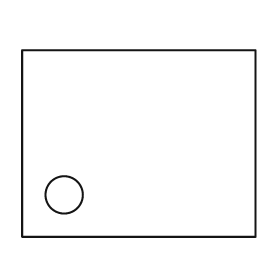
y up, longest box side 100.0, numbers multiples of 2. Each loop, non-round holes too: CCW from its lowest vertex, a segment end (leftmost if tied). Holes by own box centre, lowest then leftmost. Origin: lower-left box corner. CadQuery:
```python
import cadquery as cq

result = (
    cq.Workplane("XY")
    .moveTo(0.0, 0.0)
    .lineTo(100.0, 0.0)
    .lineTo(100.0, 80.0)
    .lineTo(0.0, 80.0)
    .close()
    .moveTo(18.0, 18.0)
    .circle(8.0)
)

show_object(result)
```